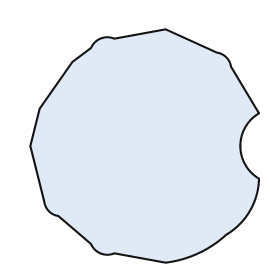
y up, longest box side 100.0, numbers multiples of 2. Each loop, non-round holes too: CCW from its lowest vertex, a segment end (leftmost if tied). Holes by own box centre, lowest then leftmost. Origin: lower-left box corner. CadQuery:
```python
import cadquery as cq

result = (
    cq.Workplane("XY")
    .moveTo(58.0, 0.0)
    .threePointArc((72.0, 4.0), (84.0, 12.0))
    .threePointArc((94.0, 22.0), (98.0, 36.0))
    .threePointArc((90.0, 50.0), (98.0, 64.0))
    .lineTo(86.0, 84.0)
    .threePointArc((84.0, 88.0), (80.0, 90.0))
    .lineTo(58.0, 100.0)
    .lineTo(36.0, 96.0)
    .threePointArc((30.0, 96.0), (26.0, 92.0))
    .lineTo(18.0, 86.0)
    .lineTo(4.0, 66.0)
    .lineTo(0.0, 50.0)
    .lineTo(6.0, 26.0)
    .threePointArc((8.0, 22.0), (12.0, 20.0))
    .lineTo(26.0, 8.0)
    .threePointArc((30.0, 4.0), (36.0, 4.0))
    .close()
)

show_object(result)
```